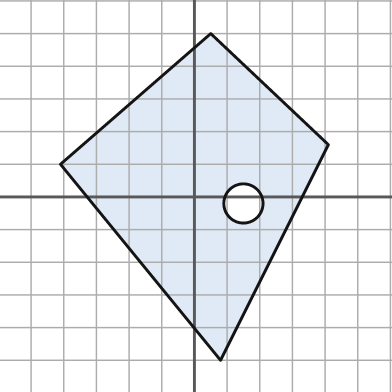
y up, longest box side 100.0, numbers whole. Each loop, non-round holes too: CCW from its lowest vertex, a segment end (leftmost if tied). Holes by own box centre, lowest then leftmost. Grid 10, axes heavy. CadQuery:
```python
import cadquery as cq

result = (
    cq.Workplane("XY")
    .moveTo(8.0, -50.0)
    .lineTo(41.0, 16.0)
    .lineTo(5.0, 50.0)
    .lineTo(-41.0, 10.0)
    .close()
    .moveTo(15.0, -2.0)
    .circle(6.0)
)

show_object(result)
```